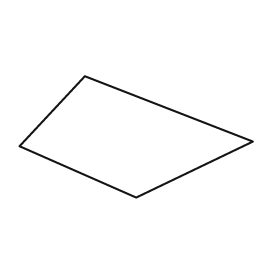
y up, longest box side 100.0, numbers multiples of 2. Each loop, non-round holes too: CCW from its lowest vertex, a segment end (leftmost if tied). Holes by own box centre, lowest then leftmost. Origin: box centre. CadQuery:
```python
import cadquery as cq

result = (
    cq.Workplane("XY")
    .moveTo(0.0, -26.0)
    .lineTo(50.0, -2.0)
    .lineTo(-22.0, 26.0)
    .lineTo(-50.0, -4.0)
    .close()
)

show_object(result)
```